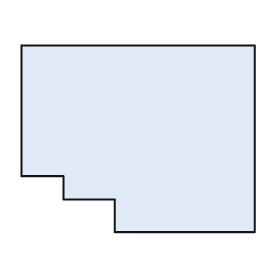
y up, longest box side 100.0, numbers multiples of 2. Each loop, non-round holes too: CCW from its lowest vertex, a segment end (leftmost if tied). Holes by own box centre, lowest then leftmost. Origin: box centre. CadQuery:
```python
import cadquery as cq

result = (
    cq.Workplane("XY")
    .moveTo(-10.0, -40.0)
    .lineTo(50.0, -40.0)
    .lineTo(50.0, 40.0)
    .lineTo(-50.0, 40.0)
    .lineTo(-50.0, -16.0)
    .lineTo(-32.0, -16.0)
    .lineTo(-32.0, -26.0)
    .lineTo(-10.0, -26.0)
    .close()
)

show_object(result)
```